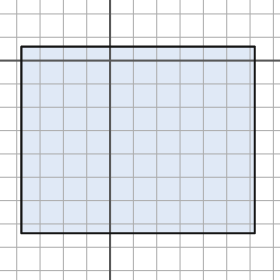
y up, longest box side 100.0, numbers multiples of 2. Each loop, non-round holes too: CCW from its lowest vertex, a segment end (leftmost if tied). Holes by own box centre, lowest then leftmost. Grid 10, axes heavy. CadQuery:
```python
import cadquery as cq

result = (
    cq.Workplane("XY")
    .moveTo(-38.0, -74.0)
    .lineTo(62.0, -74.0)
    .lineTo(62.0, 6.0)
    .lineTo(-38.0, 6.0)
    .close()
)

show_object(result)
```